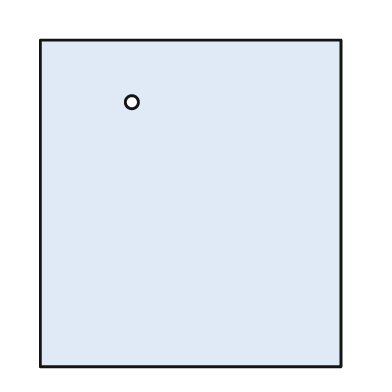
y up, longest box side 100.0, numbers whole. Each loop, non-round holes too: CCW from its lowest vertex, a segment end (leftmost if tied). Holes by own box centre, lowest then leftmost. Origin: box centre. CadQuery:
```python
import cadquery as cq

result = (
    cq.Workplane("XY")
    .moveTo(-46.0, -50.0)
    .lineTo(46.0, -50.0)
    .lineTo(46.0, 50.0)
    .lineTo(-46.0, 50.0)
    .close()
    .moveTo(-18.0, 31.0)
    .circle(2.0)
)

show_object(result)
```